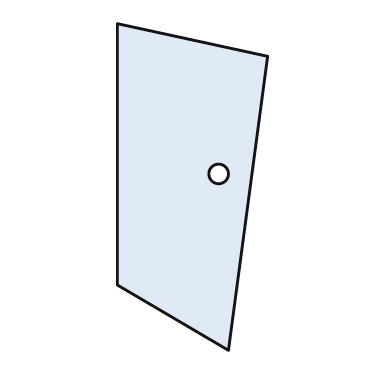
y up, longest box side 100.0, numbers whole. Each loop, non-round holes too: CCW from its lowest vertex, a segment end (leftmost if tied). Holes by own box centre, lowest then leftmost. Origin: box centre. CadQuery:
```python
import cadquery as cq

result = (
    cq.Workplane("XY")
    .moveTo(11.0, -50.0)
    .lineTo(23.0, 40.0)
    .lineTo(-23.0, 50.0)
    .lineTo(-23.0, -30.0)
    .close()
    .moveTo(8.0, 4.0)
    .circle(3.0)
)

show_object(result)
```